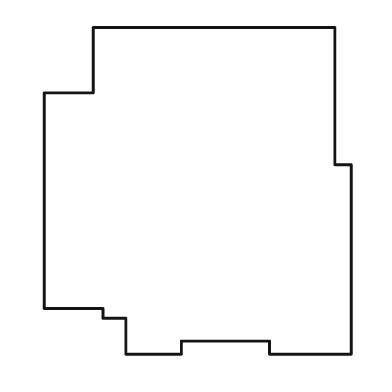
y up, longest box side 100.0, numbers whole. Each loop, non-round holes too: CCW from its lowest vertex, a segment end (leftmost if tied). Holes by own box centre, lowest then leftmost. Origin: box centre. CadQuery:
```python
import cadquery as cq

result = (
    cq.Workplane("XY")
    .moveTo(-22.0, -50.0)
    .lineTo(-5.0, -50.0)
    .lineTo(-5.0, -46.0)
    .lineTo(22.0, -46.0)
    .lineTo(22.0, -50.0)
    .lineTo(47.0, -50.0)
    .lineTo(47.0, 8.0)
    .lineTo(42.0, 8.0)
    .lineTo(42.0, 50.0)
    .lineTo(-32.0, 50.0)
    .lineTo(-32.0, 30.0)
    .lineTo(-47.0, 30.0)
    .lineTo(-47.0, -36.0)
    .lineTo(-29.0, -36.0)
    .lineTo(-29.0, -39.0)
    .lineTo(-22.0, -39.0)
    .close()
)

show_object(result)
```